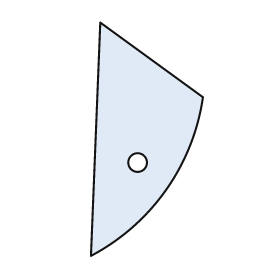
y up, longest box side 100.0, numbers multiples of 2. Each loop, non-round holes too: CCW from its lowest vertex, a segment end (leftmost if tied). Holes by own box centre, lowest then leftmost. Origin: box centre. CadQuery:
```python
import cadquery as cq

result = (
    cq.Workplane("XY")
    .moveTo(-24.0, -50.0)
    .threePointArc((8.0, -22.0), (24.0, 18.0))
    .lineTo(-20.0, 50.0)
    .close()
    .moveTo(-4.0, -10.0)
    .circle(4.0)
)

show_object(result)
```